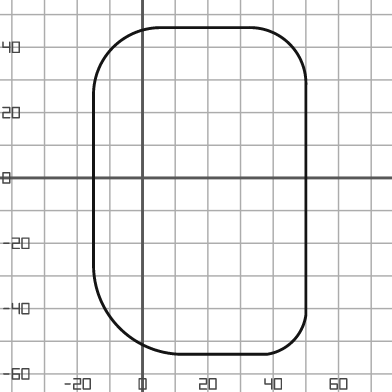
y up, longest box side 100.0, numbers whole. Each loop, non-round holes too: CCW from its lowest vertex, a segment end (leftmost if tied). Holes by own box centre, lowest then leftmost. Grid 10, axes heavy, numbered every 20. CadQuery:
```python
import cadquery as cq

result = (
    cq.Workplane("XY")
    .moveTo(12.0, -54.0)
    .lineTo(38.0, -54.0)
    .threePointArc((46.0, -50.0), (50.0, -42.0))
    .lineTo(50.0, 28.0)
    .threePointArc((45.0, 41.0), (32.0, 46.0))
    .lineTo(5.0, 46.0)
    .threePointArc((-9.0, 40.0), (-15.0, 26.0))
    .lineTo(-15.0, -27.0)
    .threePointArc((-7.0, -46.0), (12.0, -54.0))
    .close()
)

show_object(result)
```